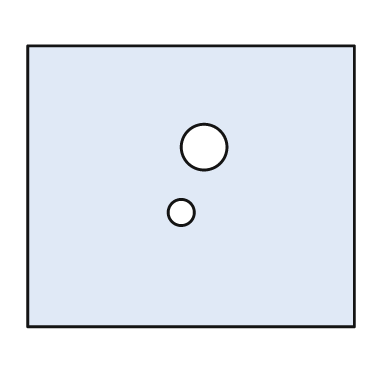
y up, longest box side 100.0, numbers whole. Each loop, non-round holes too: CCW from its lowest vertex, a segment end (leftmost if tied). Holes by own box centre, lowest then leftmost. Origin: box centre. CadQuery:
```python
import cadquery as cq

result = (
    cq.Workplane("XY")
    .moveTo(-50.0, -43.0)
    .lineTo(50.0, -43.0)
    .lineTo(50.0, 43.0)
    .lineTo(-50.0, 43.0)
    .close()
    .moveTo(-3.0, -8.0)
    .circle(4.0)
    .moveTo(4.0, 12.0)
    .circle(7.0)
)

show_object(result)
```